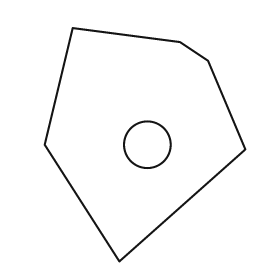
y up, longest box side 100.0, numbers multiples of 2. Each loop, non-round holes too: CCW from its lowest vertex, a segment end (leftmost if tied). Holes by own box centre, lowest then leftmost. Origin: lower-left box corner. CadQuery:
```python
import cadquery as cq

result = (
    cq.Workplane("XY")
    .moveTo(32.0, 0.0)
    .lineTo(86.0, 48.0)
    .lineTo(70.0, 86.0)
    .lineTo(58.0, 94.0)
    .lineTo(12.0, 100.0)
    .lineTo(0.0, 50.0)
    .close()
    .moveTo(44.0, 50.0)
    .circle(10.0)
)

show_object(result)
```